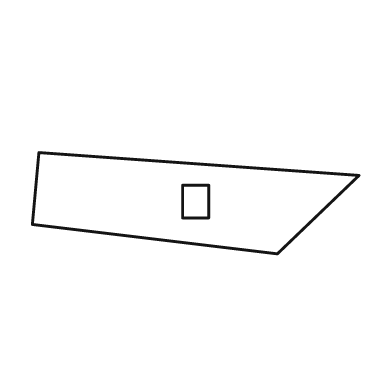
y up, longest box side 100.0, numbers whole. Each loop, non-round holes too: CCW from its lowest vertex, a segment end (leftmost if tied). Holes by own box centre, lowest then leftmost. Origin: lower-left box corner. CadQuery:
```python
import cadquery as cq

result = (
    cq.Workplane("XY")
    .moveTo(75.0, 0.0)
    .lineTo(100.0, 24.0)
    .lineTo(2.0, 31.0)
    .lineTo(0.0, 9.0)
    .close()
    .moveTo(46.0, 11.0)
    .lineTo(54.0, 11.0)
    .lineTo(54.0, 21.0)
    .lineTo(46.0, 21.0)
    .close()
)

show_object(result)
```